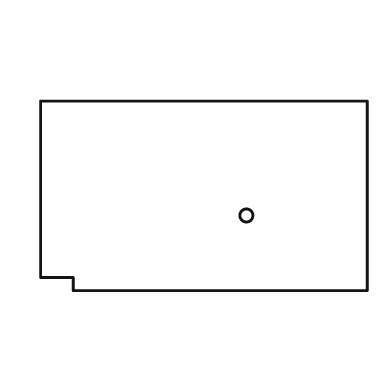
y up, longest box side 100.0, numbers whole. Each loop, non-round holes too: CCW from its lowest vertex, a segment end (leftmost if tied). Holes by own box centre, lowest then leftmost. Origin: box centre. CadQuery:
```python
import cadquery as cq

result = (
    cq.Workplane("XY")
    .moveTo(-40.0, -29.0)
    .lineTo(50.0, -29.0)
    .lineTo(50.0, 29.0)
    .lineTo(-50.0, 29.0)
    .lineTo(-50.0, -25.0)
    .lineTo(-40.0, -25.0)
    .close()
    .moveTo(13.0, -6.0)
    .circle(2.0)
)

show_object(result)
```